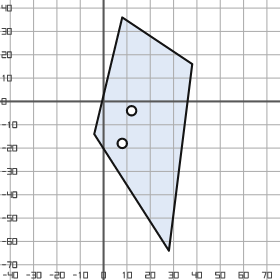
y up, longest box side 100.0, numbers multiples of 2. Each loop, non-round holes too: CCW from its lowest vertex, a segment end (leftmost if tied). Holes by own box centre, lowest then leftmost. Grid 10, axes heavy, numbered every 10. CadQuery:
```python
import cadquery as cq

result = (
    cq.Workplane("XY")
    .moveTo(28.0, -64.0)
    .lineTo(38.0, 16.0)
    .lineTo(8.0, 36.0)
    .lineTo(-4.0, -14.0)
    .close()
    .moveTo(8.0, -18.0)
    .circle(2.0)
    .moveTo(12.0, -4.0)
    .circle(2.0)
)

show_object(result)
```